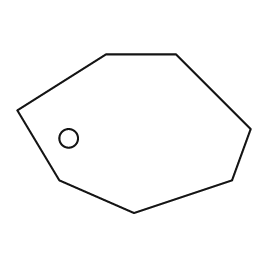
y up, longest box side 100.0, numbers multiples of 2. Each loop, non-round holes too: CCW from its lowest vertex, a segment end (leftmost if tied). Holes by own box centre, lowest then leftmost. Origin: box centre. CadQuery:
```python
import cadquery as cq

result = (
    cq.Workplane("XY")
    .moveTo(0.0, -34.0)
    .lineTo(42.0, -20.0)
    .lineTo(50.0, 2.0)
    .lineTo(18.0, 34.0)
    .lineTo(-12.0, 34.0)
    .lineTo(-50.0, 10.0)
    .lineTo(-32.0, -20.0)
    .close()
    .moveTo(-28.0, -2.0)
    .circle(4.0)
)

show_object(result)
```